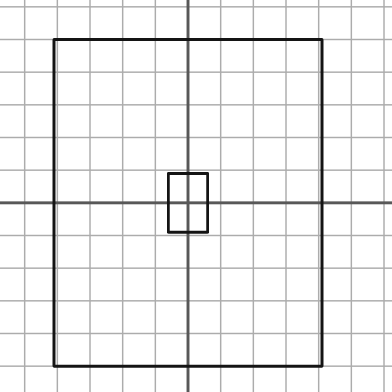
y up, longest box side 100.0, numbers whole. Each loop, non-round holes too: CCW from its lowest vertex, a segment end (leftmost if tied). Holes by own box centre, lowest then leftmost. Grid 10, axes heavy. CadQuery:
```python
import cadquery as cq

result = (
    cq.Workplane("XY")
    .moveTo(-41.0, -50.0)
    .lineTo(41.0, -50.0)
    .lineTo(41.0, 50.0)
    .lineTo(-41.0, 50.0)
    .close()
    .moveTo(-6.0, -9.0)
    .lineTo(6.0, -9.0)
    .lineTo(6.0, 9.0)
    .lineTo(-6.0, 9.0)
    .close()
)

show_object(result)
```